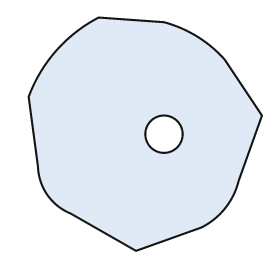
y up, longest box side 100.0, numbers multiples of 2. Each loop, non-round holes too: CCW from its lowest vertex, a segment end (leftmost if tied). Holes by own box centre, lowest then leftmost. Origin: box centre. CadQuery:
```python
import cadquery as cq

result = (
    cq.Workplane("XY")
    .moveTo(-4.0, -50.0)
    .lineTo(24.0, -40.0)
    .threePointArc((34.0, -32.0), (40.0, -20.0))
    .lineTo(50.0, 8.0)
    .lineTo(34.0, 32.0)
    .threePointArc((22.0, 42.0), (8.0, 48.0))
    .lineTo(-20.0, 50.0)
    .threePointArc((-38.0, 36.0), (-50.0, 16.0))
    .lineTo(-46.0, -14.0)
    .threePointArc((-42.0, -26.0), (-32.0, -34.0))
    .close()
    .moveTo(8.0, 0.0)
    .circle(8.0)
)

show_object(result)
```